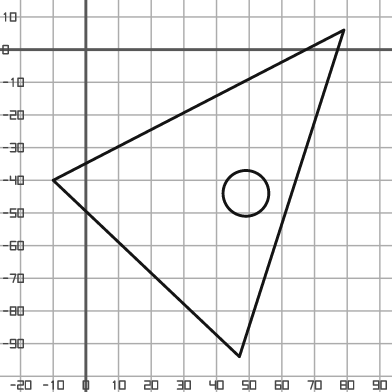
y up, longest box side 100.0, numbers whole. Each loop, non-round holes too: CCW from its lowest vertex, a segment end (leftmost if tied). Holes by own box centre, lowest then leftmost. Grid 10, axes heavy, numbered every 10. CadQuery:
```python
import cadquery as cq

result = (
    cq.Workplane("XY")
    .moveTo(47.0, -94.0)
    .lineTo(79.0, 6.0)
    .lineTo(-10.0, -40.0)
    .close()
    .moveTo(49.0, -44.0)
    .circle(7.0)
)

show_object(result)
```